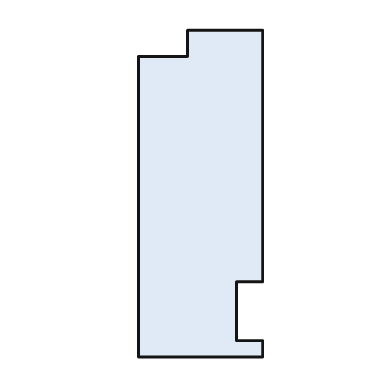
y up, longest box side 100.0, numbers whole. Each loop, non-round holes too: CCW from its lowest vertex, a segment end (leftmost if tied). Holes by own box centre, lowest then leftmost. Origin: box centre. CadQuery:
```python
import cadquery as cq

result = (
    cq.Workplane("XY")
    .moveTo(-19.0, -50.0)
    .lineTo(19.0, -50.0)
    .lineTo(19.0, -45.0)
    .lineTo(11.0, -45.0)
    .lineTo(11.0, -27.0)
    .lineTo(19.0, -27.0)
    .lineTo(19.0, 50.0)
    .lineTo(-4.0, 50.0)
    .lineTo(-4.0, 42.0)
    .lineTo(-19.0, 42.0)
    .close()
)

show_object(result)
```